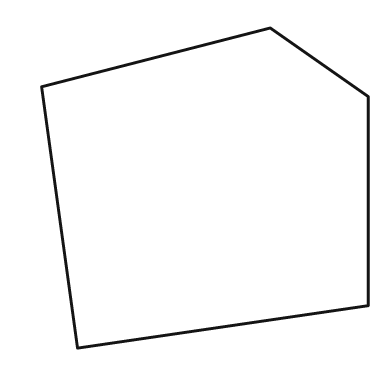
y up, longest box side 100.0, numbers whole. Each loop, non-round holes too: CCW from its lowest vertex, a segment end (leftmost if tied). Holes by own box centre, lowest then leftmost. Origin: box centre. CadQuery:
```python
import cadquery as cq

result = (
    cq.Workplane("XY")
    .moveTo(-39.0, -49.0)
    .lineTo(50.0, -36.0)
    .lineTo(50.0, 28.0)
    .lineTo(20.0, 49.0)
    .lineTo(-50.0, 31.0)
    .close()
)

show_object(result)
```